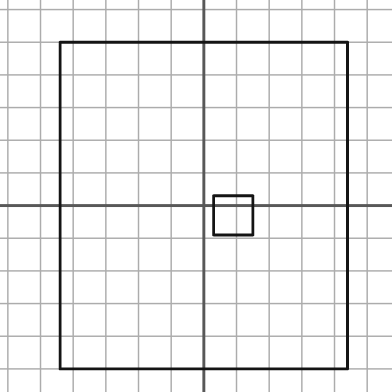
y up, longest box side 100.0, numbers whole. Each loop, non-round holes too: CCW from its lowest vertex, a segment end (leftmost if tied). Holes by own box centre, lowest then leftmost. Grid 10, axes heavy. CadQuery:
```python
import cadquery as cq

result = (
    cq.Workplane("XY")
    .moveTo(-44.0, -50.0)
    .lineTo(44.0, -50.0)
    .lineTo(44.0, 50.0)
    .lineTo(-44.0, 50.0)
    .close()
    .moveTo(3.0, -9.0)
    .lineTo(15.0, -9.0)
    .lineTo(15.0, 3.0)
    .lineTo(3.0, 3.0)
    .close()
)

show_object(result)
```